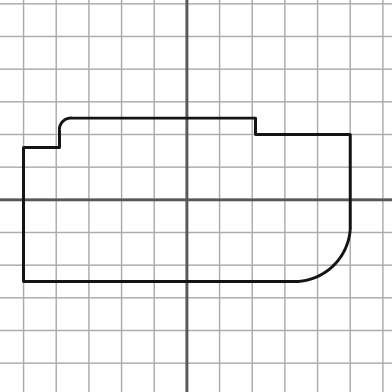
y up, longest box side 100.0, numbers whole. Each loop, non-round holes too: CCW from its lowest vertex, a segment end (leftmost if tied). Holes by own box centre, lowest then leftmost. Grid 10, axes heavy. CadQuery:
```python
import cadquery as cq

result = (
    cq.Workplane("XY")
    .moveTo(-50.0, -25.0)
    .lineTo(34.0, -25.0)
    .threePointArc((45.0, -20.0), (50.0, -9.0))
    .lineTo(50.0, 20.0)
    .lineTo(21.0, 20.0)
    .lineTo(21.0, 25.0)
    .lineTo(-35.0, 25.0)
    .threePointArc((-38.0, 24.0), (-39.0, 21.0))
    .lineTo(-39.0, 16.0)
    .lineTo(-50.0, 16.0)
    .close()
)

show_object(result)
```